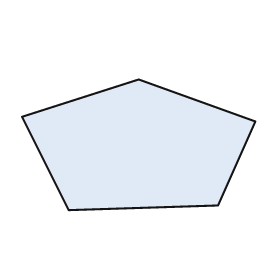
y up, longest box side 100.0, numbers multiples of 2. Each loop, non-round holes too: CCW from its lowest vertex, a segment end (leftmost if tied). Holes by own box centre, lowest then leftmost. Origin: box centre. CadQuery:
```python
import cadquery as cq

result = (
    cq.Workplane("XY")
    .moveTo(-30.0, -28.0)
    .lineTo(34.0, -26.0)
    .lineTo(50.0, 10.0)
    .lineTo(0.0, 28.0)
    .lineTo(-50.0, 12.0)
    .close()
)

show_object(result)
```